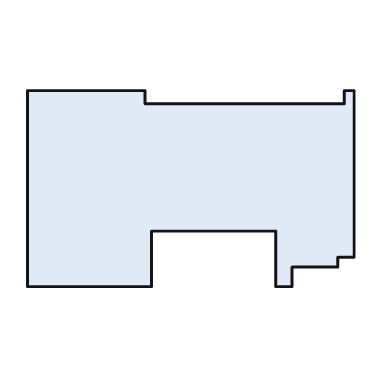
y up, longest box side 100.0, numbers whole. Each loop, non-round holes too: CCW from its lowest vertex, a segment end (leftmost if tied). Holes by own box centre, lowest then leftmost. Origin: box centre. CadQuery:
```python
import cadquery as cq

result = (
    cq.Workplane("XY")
    .moveTo(-50.0, -30.0)
    .lineTo(-12.0, -30.0)
    .lineTo(-12.0, -13.0)
    .lineTo(26.0, -13.0)
    .lineTo(26.0, -30.0)
    .lineTo(31.0, -30.0)
    .lineTo(31.0, -24.0)
    .lineTo(45.0, -24.0)
    .lineTo(45.0, -21.0)
    .lineTo(50.0, -21.0)
    .lineTo(50.0, 30.0)
    .lineTo(47.0, 30.0)
    .lineTo(47.0, 26.0)
    .lineTo(-14.0, 26.0)
    .lineTo(-14.0, 30.0)
    .lineTo(-50.0, 30.0)
    .close()
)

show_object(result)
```